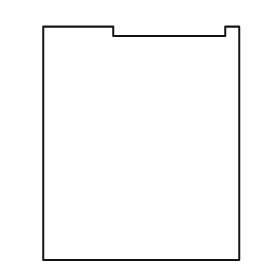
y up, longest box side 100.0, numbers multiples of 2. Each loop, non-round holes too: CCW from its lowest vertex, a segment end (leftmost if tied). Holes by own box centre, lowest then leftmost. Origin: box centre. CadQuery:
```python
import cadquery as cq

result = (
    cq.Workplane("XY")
    .moveTo(-42.0, -50.0)
    .lineTo(42.0, -50.0)
    .lineTo(42.0, 50.0)
    .lineTo(36.0, 50.0)
    .lineTo(36.0, 46.0)
    .lineTo(-12.0, 46.0)
    .lineTo(-12.0, 50.0)
    .lineTo(-42.0, 50.0)
    .close()
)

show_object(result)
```